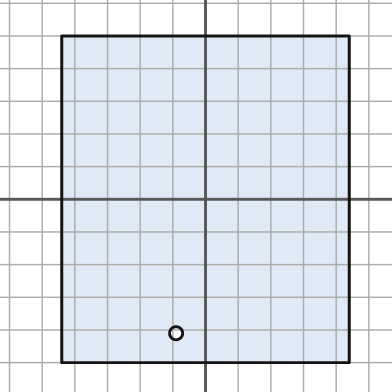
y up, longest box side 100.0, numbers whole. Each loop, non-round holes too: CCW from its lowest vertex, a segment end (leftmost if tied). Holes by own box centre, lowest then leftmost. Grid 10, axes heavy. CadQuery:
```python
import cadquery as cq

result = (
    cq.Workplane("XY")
    .moveTo(-44.0, -50.0)
    .lineTo(44.0, -50.0)
    .lineTo(44.0, 50.0)
    .lineTo(-44.0, 50.0)
    .close()
    .moveTo(-9.0, -41.0)
    .circle(2.0)
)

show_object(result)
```